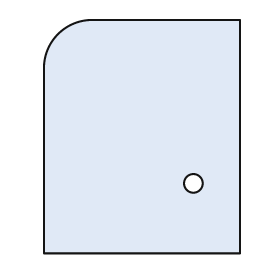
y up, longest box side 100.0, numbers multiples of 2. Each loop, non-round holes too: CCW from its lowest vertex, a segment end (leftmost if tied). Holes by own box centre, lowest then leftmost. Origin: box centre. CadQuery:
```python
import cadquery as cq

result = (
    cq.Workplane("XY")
    .moveTo(-42.0, -50.0)
    .lineTo(42.0, -50.0)
    .lineTo(42.0, 50.0)
    .lineTo(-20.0, 50.0)
    .threePointArc((-36.0, 44.0), (-42.0, 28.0))
    .close()
    .moveTo(22.0, -20.0)
    .circle(4.0)
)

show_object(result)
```